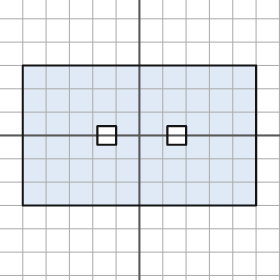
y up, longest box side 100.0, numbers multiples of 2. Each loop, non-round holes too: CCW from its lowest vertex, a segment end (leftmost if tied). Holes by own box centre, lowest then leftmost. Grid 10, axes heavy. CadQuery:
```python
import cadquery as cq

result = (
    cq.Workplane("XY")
    .moveTo(-50.0, -30.0)
    .lineTo(50.0, -30.0)
    .lineTo(50.0, 30.0)
    .lineTo(-50.0, 30.0)
    .close()
    .moveTo(-18.0, -4.0)
    .lineTo(-10.0, -4.0)
    .lineTo(-10.0, 4.0)
    .lineTo(-18.0, 4.0)
    .close()
    .moveTo(12.0, -4.0)
    .lineTo(20.0, -4.0)
    .lineTo(20.0, 4.0)
    .lineTo(12.0, 4.0)
    .close()
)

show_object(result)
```